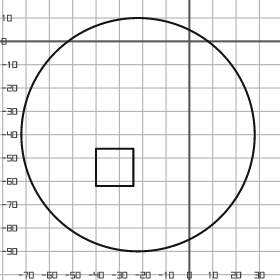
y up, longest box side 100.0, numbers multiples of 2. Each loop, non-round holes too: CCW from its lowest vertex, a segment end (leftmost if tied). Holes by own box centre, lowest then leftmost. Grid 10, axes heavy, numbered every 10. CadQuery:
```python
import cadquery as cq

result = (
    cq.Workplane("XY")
    .moveTo(-22.0, -40.0)
    .circle(50.0)
    .moveTo(-40.0, -62.0)
    .lineTo(-24.0, -62.0)
    .lineTo(-24.0, -46.0)
    .lineTo(-40.0, -46.0)
    .close()
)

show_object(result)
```